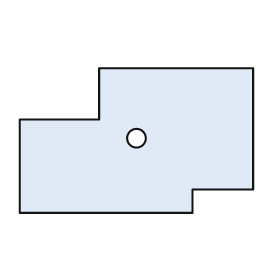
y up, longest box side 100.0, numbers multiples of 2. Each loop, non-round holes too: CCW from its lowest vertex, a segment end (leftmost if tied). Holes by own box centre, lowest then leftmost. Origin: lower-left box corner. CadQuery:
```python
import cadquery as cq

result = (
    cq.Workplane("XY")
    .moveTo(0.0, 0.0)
    .lineTo(74.0, 0.0)
    .lineTo(74.0, 10.0)
    .lineTo(100.0, 10.0)
    .lineTo(100.0, 62.0)
    .lineTo(34.0, 62.0)
    .lineTo(34.0, 40.0)
    .lineTo(0.0, 40.0)
    .close()
    .moveTo(50.0, 32.0)
    .circle(4.0)
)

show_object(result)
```